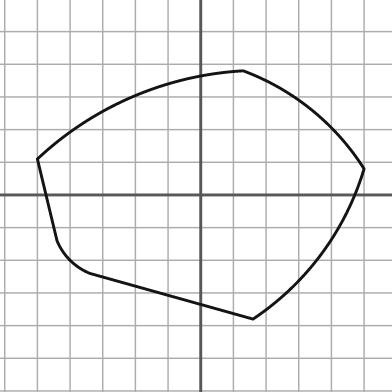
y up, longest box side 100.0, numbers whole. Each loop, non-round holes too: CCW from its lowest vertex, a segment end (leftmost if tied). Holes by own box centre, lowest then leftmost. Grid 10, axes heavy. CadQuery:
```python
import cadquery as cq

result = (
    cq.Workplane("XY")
    .moveTo(16.0, -38.0)
    .threePointArc((37.0, -18.0), (50.0, 8.0))
    .threePointArc((34.0, 26.0), (13.0, 38.0))
    .threePointArc((-21.0, 30.0), (-50.0, 11.0))
    .lineTo(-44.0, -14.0)
    .threePointArc((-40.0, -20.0), (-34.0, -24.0))
    .close()
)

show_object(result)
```